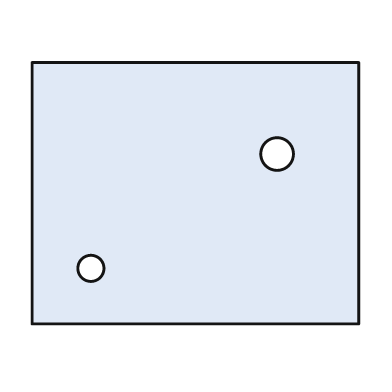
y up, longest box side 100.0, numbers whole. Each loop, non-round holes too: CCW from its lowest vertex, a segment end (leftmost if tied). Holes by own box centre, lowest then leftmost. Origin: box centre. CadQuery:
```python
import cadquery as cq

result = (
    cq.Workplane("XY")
    .moveTo(-50.0, -40.0)
    .lineTo(50.0, -40.0)
    .lineTo(50.0, 40.0)
    .lineTo(-50.0, 40.0)
    .close()
    .moveTo(-32.0, -23.0)
    .circle(4.0)
    .moveTo(25.0, 12.0)
    .circle(5.0)
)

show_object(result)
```